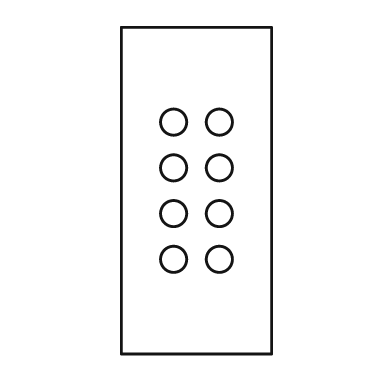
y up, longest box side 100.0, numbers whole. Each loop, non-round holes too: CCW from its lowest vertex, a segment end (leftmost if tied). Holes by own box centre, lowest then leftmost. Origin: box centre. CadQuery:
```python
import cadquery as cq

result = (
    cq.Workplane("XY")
    .moveTo(-23.0, -50.0)
    .lineTo(23.0, -50.0)
    .lineTo(23.0, 50.0)
    .lineTo(-23.0, 50.0)
    .close()
    .moveTo(-7.0, -21.0)
    .circle(4.0)
    .moveTo(7.0, -21.0)
    .circle(4.0)
    .moveTo(-7.0, -7.0)
    .circle(4.0)
    .moveTo(7.0, -7.0)
    .circle(4.0)
    .moveTo(-7.0, 7.0)
    .circle(4.0)
    .moveTo(7.0, 7.0)
    .circle(4.0)
    .moveTo(-7.0, 21.0)
    .circle(4.0)
    .moveTo(7.0, 21.0)
    .circle(4.0)
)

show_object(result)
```